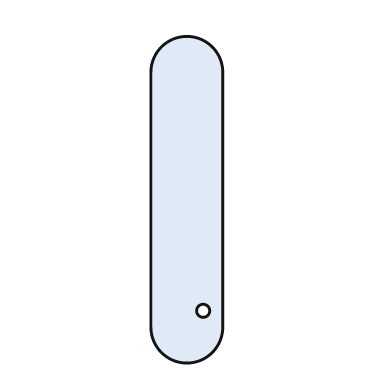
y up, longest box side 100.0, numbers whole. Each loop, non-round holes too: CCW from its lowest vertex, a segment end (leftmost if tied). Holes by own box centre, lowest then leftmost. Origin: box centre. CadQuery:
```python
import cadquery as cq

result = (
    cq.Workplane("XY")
    .moveTo(-11.0, -39.0)
    .threePointArc((0.0, -50.0), (11.0, -39.0))
    .lineTo(11.0, 39.0)
    .threePointArc((0.0, 50.0), (-11.0, 39.0))
    .close()
    .moveTo(5.0, -34.0)
    .circle(2.0)
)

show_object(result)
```